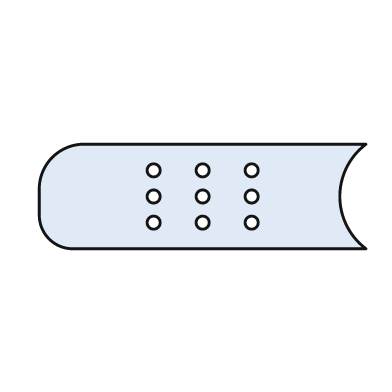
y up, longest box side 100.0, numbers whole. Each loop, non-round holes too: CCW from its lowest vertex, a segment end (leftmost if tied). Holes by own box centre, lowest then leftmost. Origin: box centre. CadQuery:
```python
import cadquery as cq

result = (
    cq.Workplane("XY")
    .moveTo(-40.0, -16.0)
    .lineTo(50.0, -16.0)
    .threePointArc((42.0, 0.0), (50.0, 16.0))
    .lineTo(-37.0, 16.0)
    .threePointArc((-46.0, 12.0), (-50.0, 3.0))
    .lineTo(-50.0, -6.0)
    .threePointArc((-47.0, -13.0), (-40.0, -16.0))
    .close()
    .moveTo(-15.0, -8.0)
    .circle(2.0)
    .moveTo(0.0, -8.0)
    .circle(2.0)
    .moveTo(15.0, -8.0)
    .circle(2.0)
    .moveTo(-15.0, 0.0)
    .circle(2.0)
    .moveTo(0.0, 0.0)
    .circle(2.0)
    .moveTo(15.0, 0.0)
    .circle(2.0)
    .moveTo(-15.0, 8.0)
    .circle(2.0)
    .moveTo(0.0, 8.0)
    .circle(2.0)
    .moveTo(15.0, 8.0)
    .circle(2.0)
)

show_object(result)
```